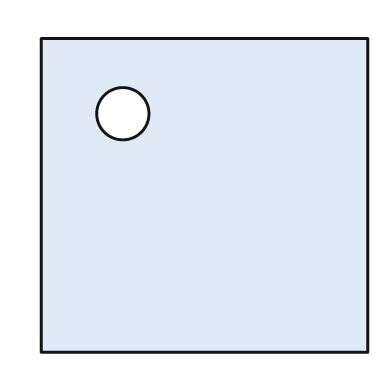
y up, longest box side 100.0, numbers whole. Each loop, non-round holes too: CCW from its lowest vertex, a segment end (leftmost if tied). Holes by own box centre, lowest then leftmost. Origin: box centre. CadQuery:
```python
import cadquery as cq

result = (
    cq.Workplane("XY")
    .moveTo(-50.0, -48.0)
    .lineTo(50.0, -48.0)
    .lineTo(50.0, 48.0)
    .lineTo(-50.0, 48.0)
    .close()
    .moveTo(-25.0, 25.0)
    .circle(8.0)
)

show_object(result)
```